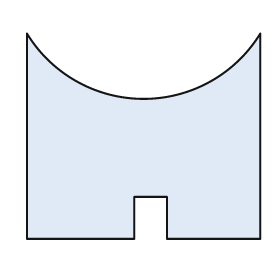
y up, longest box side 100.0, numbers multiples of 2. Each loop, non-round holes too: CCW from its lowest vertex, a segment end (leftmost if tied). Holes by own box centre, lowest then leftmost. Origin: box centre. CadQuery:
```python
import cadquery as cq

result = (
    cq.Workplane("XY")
    .moveTo(-50.0, -44.0)
    .lineTo(-4.0, -44.0)
    .lineTo(-4.0, -26.0)
    .lineTo(10.0, -26.0)
    .lineTo(10.0, -44.0)
    .lineTo(50.0, -44.0)
    .lineTo(50.0, 44.0)
    .threePointArc((0.0, 16.0), (-50.0, 44.0))
    .close()
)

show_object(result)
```